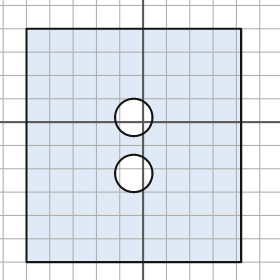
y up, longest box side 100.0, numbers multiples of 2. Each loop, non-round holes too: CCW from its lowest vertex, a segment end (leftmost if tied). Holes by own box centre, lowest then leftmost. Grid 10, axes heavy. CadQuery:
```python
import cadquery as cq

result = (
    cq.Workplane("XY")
    .moveTo(-50.0, -60.0)
    .lineTo(42.0, -60.0)
    .lineTo(42.0, 40.0)
    .lineTo(-50.0, 40.0)
    .close()
    .moveTo(-4.0, -22.0)
    .circle(8.0)
    .moveTo(-4.0, 2.0)
    .circle(8.0)
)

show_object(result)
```